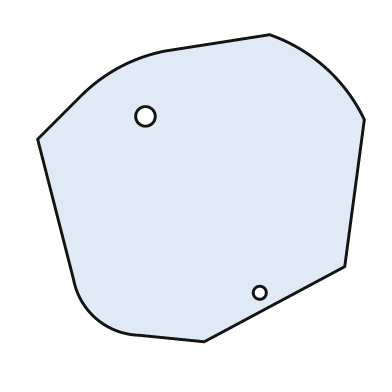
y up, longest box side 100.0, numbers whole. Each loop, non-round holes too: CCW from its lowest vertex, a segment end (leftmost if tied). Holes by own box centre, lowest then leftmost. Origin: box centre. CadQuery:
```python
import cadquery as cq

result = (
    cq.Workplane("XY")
    .moveTo(1.0, -47.0)
    .lineTo(44.0, -24.0)
    .lineTo(50.0, 21.0)
    .threePointArc((38.0, 37.0), (21.0, 47.0))
    .lineTo(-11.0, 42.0)
    .threePointArc((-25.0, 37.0), (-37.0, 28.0))
    .lineTo(-50.0, 15.0)
    .lineTo(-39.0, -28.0)
    .threePointArc((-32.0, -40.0), (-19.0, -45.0))
    .close()
    .moveTo(18.0, -32.0)
    .circle(2.0)
    .moveTo(-17.0, 22.0)
    .circle(3.0)
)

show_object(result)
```